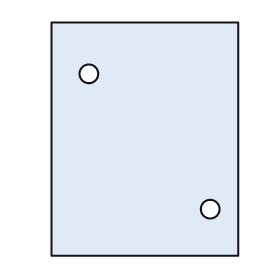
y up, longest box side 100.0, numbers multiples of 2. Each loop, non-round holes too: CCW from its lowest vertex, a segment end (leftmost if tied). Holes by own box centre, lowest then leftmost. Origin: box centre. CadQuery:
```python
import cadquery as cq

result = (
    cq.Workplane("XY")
    .moveTo(-40.0, -50.0)
    .lineTo(40.0, -50.0)
    .lineTo(40.0, 50.0)
    .lineTo(-40.0, 50.0)
    .close()
    .moveTo(28.0, -30.0)
    .circle(4.0)
    .moveTo(-24.0, 28.0)
    .circle(4.0)
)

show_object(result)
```